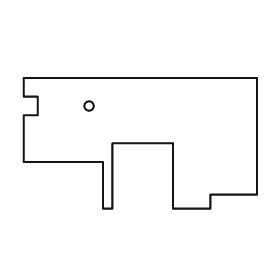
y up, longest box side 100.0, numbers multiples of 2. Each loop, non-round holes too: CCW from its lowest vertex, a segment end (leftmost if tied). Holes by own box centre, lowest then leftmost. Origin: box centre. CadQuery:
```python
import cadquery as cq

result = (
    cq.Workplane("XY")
    .moveTo(-16.0, -28.0)
    .lineTo(-12.0, -28.0)
    .lineTo(-12.0, 0.0)
    .lineTo(14.0, 0.0)
    .lineTo(14.0, -28.0)
    .lineTo(30.0, -28.0)
    .lineTo(30.0, -22.0)
    .lineTo(50.0, -22.0)
    .lineTo(50.0, 28.0)
    .lineTo(-50.0, 28.0)
    .lineTo(-50.0, 20.0)
    .lineTo(-44.0, 20.0)
    .lineTo(-44.0, 12.0)
    .lineTo(-50.0, 12.0)
    .lineTo(-50.0, -8.0)
    .lineTo(-16.0, -8.0)
    .close()
    .moveTo(-22.0, 16.0)
    .circle(2.0)
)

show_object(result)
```